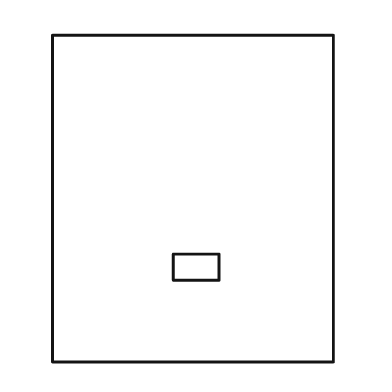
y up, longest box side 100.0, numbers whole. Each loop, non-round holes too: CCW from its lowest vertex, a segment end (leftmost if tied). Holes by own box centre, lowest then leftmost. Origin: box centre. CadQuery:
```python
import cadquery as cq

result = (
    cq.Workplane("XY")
    .moveTo(-43.0, -50.0)
    .lineTo(43.0, -50.0)
    .lineTo(43.0, 50.0)
    .lineTo(-43.0, 50.0)
    .close()
    .moveTo(-6.0, -25.0)
    .lineTo(8.0, -25.0)
    .lineTo(8.0, -17.0)
    .lineTo(-6.0, -17.0)
    .close()
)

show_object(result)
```